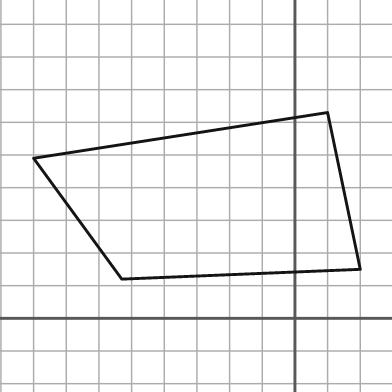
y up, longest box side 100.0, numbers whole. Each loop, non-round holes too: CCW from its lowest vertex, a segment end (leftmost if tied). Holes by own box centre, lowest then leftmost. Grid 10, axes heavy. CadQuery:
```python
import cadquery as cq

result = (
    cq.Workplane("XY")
    .moveTo(-53.0, 12.0)
    .lineTo(20.0, 15.0)
    .lineTo(10.0, 63.0)
    .lineTo(-80.0, 49.0)
    .close()
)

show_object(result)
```